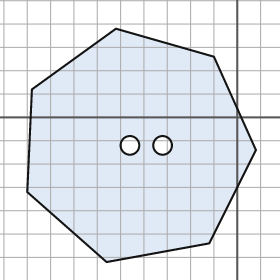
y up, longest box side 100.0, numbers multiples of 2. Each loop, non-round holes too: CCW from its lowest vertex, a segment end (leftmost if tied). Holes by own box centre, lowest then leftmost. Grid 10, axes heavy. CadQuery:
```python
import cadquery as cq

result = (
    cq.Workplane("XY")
    .moveTo(-56.0, -62.0)
    .lineTo(-12.0, -54.0)
    .lineTo(8.0, -14.0)
    .lineTo(-10.0, 26.0)
    .lineTo(-52.0, 38.0)
    .lineTo(-88.0, 12.0)
    .lineTo(-90.0, -32.0)
    .close()
    .moveTo(-46.0, -12.0)
    .circle(4.0)
    .moveTo(-32.0, -12.0)
    .circle(4.0)
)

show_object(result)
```